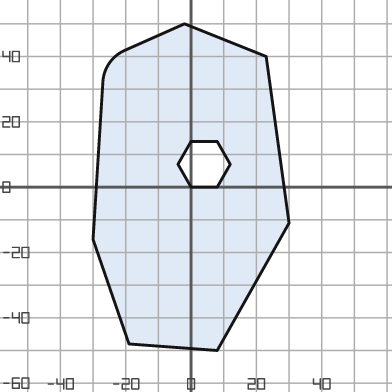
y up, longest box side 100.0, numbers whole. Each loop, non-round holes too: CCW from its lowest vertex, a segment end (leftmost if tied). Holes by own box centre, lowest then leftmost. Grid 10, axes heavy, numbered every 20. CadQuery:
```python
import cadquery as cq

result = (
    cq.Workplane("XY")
    .moveTo(8.0, -50.0)
    .lineTo(30.0, -11.0)
    .lineTo(23.0, 40.0)
    .lineTo(-2.0, 50.0)
    .lineTo(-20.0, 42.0)
    .threePointArc((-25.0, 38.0), (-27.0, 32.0))
    .lineTo(-30.0, -16.0)
    .lineTo(-19.0, -48.0)
    .close()
    .moveTo(0.0, 0.0)
    .lineTo(8.0, 0.0)
    .lineTo(12.0, 7.0)
    .lineTo(8.0, 14.0)
    .lineTo(0.0, 14.0)
    .lineTo(-4.0, 7.0)
    .close()
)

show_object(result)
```